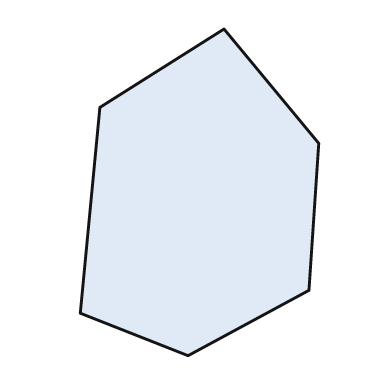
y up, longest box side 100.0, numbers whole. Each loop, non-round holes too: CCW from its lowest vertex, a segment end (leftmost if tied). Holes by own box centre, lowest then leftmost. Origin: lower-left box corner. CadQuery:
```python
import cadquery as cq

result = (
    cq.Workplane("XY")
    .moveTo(33.0, 0.0)
    .lineTo(70.0, 20.0)
    .lineTo(73.0, 65.0)
    .lineTo(44.0, 100.0)
    .lineTo(6.0, 76.0)
    .lineTo(0.0, 13.0)
    .close()
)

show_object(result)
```